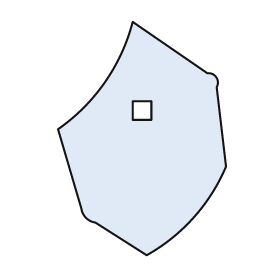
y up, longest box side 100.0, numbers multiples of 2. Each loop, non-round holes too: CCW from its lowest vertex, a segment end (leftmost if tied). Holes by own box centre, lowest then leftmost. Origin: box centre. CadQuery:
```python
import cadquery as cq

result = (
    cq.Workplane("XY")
    .moveTo(2.0, -50.0)
    .threePointArc((22.0, -34.0), (36.0, -12.0))
    .lineTo(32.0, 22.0)
    .threePointArc((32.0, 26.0), (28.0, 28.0))
    .lineTo(-4.0, 50.0)
    .threePointArc((-16.0, 24.0), (-36.0, 4.0))
    .lineTo(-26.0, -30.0)
    .threePointArc((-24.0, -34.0), (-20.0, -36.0))
    .close()
    .moveTo(-4.0, 8.0)
    .lineTo(4.0, 8.0)
    .lineTo(4.0, 16.0)
    .lineTo(-4.0, 16.0)
    .close()
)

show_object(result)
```